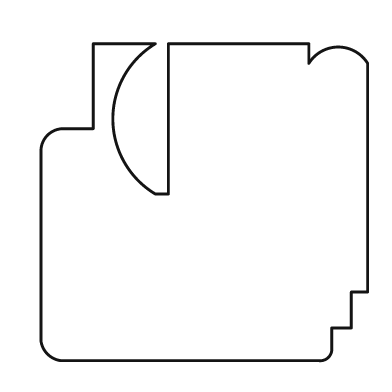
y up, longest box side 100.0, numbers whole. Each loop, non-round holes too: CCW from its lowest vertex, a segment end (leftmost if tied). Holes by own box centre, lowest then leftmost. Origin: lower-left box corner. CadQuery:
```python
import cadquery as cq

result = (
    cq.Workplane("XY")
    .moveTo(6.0, 0.0)
    .lineTo(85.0, 0.0)
    .threePointArc((88.0, 1.0), (89.0, 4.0))
    .lineTo(89.0, 10.0)
    .lineTo(95.0, 10.0)
    .lineTo(95.0, 21.0)
    .lineTo(100.0, 21.0)
    .lineTo(100.0, 91.0)
    .threePointArc((91.0, 96.0), (82.0, 91.0))
    .lineTo(82.0, 97.0)
    .lineTo(39.0, 97.0)
    .lineTo(39.0, 51.0)
    .lineTo(35.0, 51.0)
    .threePointArc((22.0, 74.0), (35.0, 97.0))
    .lineTo(16.0, 97.0)
    .lineTo(16.0, 71.0)
    .lineTo(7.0, 71.0)
    .threePointArc((2.0, 69.0), (0.0, 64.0))
    .lineTo(0.0, 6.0)
    .threePointArc((2.0, 2.0), (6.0, 0.0))
    .close()
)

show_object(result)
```